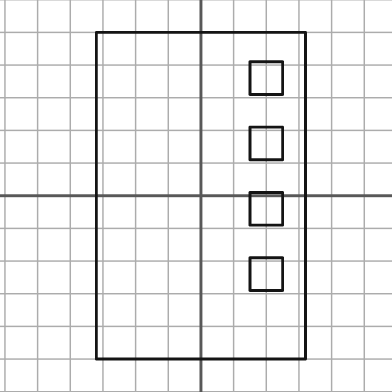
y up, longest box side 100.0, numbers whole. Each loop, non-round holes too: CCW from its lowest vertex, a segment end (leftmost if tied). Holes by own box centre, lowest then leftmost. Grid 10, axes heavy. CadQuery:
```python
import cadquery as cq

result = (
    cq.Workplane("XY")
    .moveTo(-32.0, -50.0)
    .lineTo(32.0, -50.0)
    .lineTo(32.0, 50.0)
    .lineTo(-32.0, 50.0)
    .close()
    .moveTo(15.0, -29.0)
    .lineTo(25.0, -29.0)
    .lineTo(25.0, -19.0)
    .lineTo(15.0, -19.0)
    .close()
    .moveTo(15.0, -9.0)
    .lineTo(25.0, -9.0)
    .lineTo(25.0, 1.0)
    .lineTo(15.0, 1.0)
    .close()
    .moveTo(15.0, 11.0)
    .lineTo(25.0, 11.0)
    .lineTo(25.0, 21.0)
    .lineTo(15.0, 21.0)
    .close()
    .moveTo(15.0, 31.0)
    .lineTo(25.0, 31.0)
    .lineTo(25.0, 41.0)
    .lineTo(15.0, 41.0)
    .close()
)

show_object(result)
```